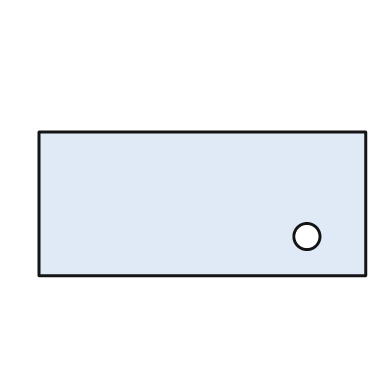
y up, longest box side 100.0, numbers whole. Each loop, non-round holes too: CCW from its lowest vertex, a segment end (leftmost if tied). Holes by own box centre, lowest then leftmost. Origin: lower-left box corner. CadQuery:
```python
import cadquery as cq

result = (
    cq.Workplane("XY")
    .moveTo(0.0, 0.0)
    .lineTo(100.0, 0.0)
    .lineTo(100.0, 44.0)
    .lineTo(0.0, 44.0)
    .close()
    .moveTo(82.0, 12.0)
    .circle(4.0)
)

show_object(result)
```